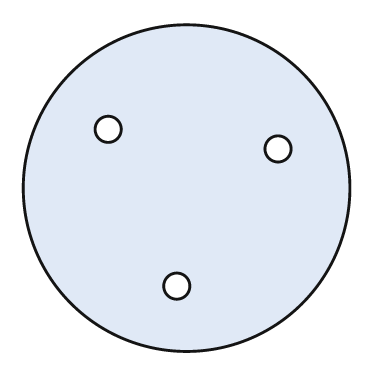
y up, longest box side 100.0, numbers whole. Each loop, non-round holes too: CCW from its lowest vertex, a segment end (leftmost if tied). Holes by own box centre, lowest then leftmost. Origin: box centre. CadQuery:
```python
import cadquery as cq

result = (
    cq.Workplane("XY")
    .moveTo(0.0, 0.0)
    .circle(50.0)
    .moveTo(-3.0, -30.0)
    .circle(4.0)
    .moveTo(28.0, 12.0)
    .circle(4.0)
    .moveTo(-24.0, 18.0)
    .circle(4.0)
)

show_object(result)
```